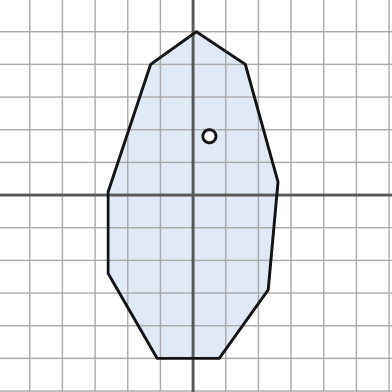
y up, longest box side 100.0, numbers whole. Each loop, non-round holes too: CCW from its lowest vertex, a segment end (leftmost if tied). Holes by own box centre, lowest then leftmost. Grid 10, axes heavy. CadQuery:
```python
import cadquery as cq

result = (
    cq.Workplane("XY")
    .moveTo(-11.0, -50.0)
    .lineTo(8.0, -50.0)
    .lineTo(23.0, -29.0)
    .lineTo(26.0, 4.0)
    .lineTo(16.0, 40.0)
    .lineTo(1.0, 50.0)
    .lineTo(-13.0, 40.0)
    .lineTo(-26.0, 1.0)
    .lineTo(-26.0, -24.0)
    .close()
    .moveTo(5.0, 18.0)
    .circle(2.0)
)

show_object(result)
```